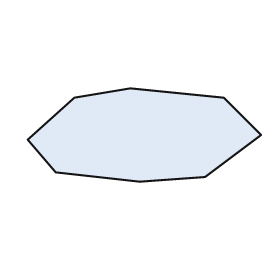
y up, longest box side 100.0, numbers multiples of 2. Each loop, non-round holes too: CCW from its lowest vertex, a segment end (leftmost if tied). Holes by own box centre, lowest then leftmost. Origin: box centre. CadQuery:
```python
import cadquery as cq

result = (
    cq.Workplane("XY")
    .moveTo(-2.0, -20.0)
    .lineTo(26.0, -18.0)
    .lineTo(50.0, 0.0)
    .lineTo(34.0, 16.0)
    .lineTo(-6.0, 20.0)
    .lineTo(-30.0, 16.0)
    .lineTo(-50.0, -2.0)
    .lineTo(-38.0, -16.0)
    .close()
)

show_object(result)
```